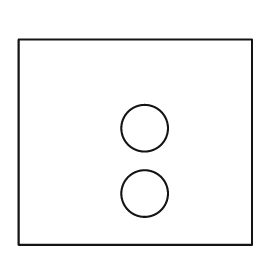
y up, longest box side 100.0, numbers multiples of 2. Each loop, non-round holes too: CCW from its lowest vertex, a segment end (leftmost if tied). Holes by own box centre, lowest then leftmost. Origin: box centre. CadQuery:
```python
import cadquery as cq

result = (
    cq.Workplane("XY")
    .moveTo(-50.0, -44.0)
    .lineTo(50.0, -44.0)
    .lineTo(50.0, 44.0)
    .lineTo(-50.0, 44.0)
    .close()
    .moveTo(4.0, -22.0)
    .circle(10.0)
    .moveTo(4.0, 6.0)
    .circle(10.0)
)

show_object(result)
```